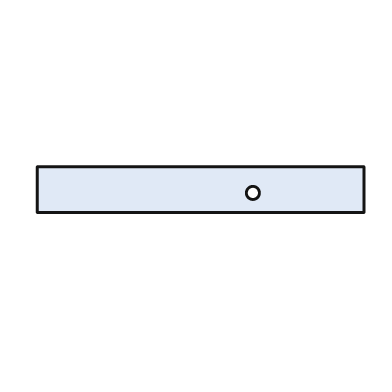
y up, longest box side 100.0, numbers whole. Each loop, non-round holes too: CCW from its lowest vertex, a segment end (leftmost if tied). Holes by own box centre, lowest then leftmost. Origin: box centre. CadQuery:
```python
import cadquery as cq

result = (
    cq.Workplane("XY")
    .moveTo(-50.0, -7.0)
    .lineTo(50.0, -7.0)
    .lineTo(50.0, 7.0)
    .lineTo(-50.0, 7.0)
    .close()
    .moveTo(16.0, -1.0)
    .circle(2.0)
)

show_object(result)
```